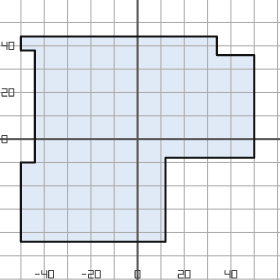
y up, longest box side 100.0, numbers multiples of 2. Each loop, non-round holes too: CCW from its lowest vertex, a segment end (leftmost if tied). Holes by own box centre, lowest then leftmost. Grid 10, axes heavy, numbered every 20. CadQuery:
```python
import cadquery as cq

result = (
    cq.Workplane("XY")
    .moveTo(-50.0, -44.0)
    .lineTo(12.0, -44.0)
    .lineTo(12.0, -8.0)
    .lineTo(50.0, -8.0)
    .lineTo(50.0, 36.0)
    .lineTo(34.0, 36.0)
    .lineTo(34.0, 44.0)
    .lineTo(-50.0, 44.0)
    .lineTo(-50.0, 38.0)
    .lineTo(-44.0, 38.0)
    .lineTo(-44.0, -10.0)
    .lineTo(-50.0, -10.0)
    .close()
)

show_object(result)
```